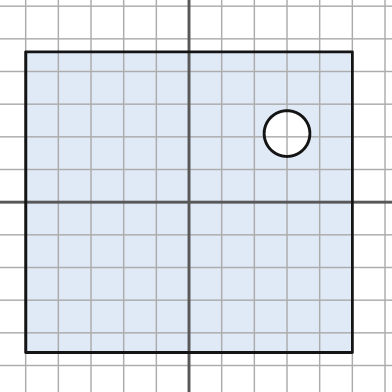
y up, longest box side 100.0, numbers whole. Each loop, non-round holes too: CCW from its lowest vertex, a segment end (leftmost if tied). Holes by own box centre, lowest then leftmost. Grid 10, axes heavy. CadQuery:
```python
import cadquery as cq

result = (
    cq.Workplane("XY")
    .moveTo(-50.0, -46.0)
    .lineTo(50.0, -46.0)
    .lineTo(50.0, 46.0)
    .lineTo(-50.0, 46.0)
    .close()
    .moveTo(30.0, 21.0)
    .circle(7.0)
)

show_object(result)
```